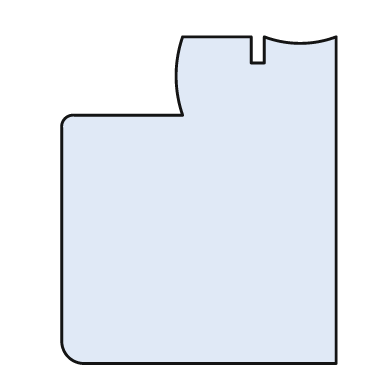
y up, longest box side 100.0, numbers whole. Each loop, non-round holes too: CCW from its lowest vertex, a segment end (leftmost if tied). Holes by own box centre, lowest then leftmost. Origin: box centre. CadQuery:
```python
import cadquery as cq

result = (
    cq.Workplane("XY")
    .moveTo(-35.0, -50.0)
    .lineTo(42.0, -50.0)
    .lineTo(42.0, 50.0)
    .threePointArc((31.0, 48.0), (20.0, 50.0))
    .lineTo(20.0, 42.0)
    .lineTo(16.0, 42.0)
    .lineTo(16.0, 50.0)
    .lineTo(-5.0, 50.0)
    .threePointArc((-7.0, 38.0), (-5.0, 26.0))
    .lineTo(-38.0, 26.0)
    .threePointArc((-41.0, 25.0), (-42.0, 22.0))
    .lineTo(-42.0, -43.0)
    .threePointArc((-40.0, -48.0), (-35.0, -50.0))
    .close()
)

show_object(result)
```